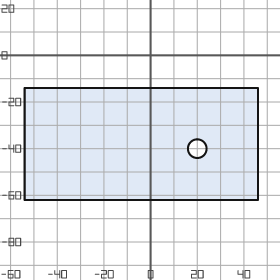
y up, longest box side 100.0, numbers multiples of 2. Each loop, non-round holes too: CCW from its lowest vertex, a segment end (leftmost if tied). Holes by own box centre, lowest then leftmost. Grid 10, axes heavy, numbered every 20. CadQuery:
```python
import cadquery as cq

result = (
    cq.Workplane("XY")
    .moveTo(-54.0, -62.0)
    .lineTo(46.0, -62.0)
    .lineTo(46.0, -14.0)
    .lineTo(-54.0, -14.0)
    .close()
    .moveTo(20.0, -40.0)
    .circle(4.0)
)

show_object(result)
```